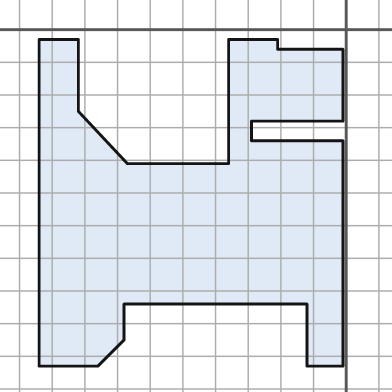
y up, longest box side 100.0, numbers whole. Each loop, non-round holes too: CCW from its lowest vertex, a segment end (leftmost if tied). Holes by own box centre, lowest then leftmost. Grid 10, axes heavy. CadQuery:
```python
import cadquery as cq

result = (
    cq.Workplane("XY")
    .moveTo(-94.0, -103.0)
    .lineTo(-76.0, -103.0)
    .lineTo(-68.0, -95.0)
    .lineTo(-68.0, -84.0)
    .lineTo(-12.0, -84.0)
    .lineTo(-12.0, -103.0)
    .lineTo(-1.0, -103.0)
    .lineTo(-1.0, -34.0)
    .lineTo(-29.0, -34.0)
    .lineTo(-29.0, -28.0)
    .lineTo(-1.0, -28.0)
    .lineTo(-1.0, -6.0)
    .lineTo(-21.0, -6.0)
    .lineTo(-21.0, -3.0)
    .lineTo(-36.0, -3.0)
    .lineTo(-36.0, -41.0)
    .lineTo(-67.0, -41.0)
    .lineTo(-82.0, -25.0)
    .lineTo(-82.0, -3.0)
    .lineTo(-94.0, -3.0)
    .close()
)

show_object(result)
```